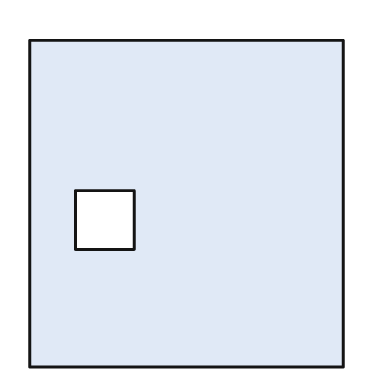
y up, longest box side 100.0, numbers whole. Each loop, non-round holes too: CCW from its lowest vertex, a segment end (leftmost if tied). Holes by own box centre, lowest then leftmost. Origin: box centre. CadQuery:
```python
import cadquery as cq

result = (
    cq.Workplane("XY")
    .moveTo(-48.0, -50.0)
    .lineTo(48.0, -50.0)
    .lineTo(48.0, 50.0)
    .lineTo(-48.0, 50.0)
    .close()
    .moveTo(-34.0, -14.0)
    .lineTo(-16.0, -14.0)
    .lineTo(-16.0, 4.0)
    .lineTo(-34.0, 4.0)
    .close()
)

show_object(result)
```